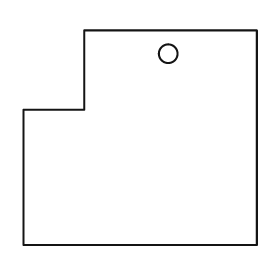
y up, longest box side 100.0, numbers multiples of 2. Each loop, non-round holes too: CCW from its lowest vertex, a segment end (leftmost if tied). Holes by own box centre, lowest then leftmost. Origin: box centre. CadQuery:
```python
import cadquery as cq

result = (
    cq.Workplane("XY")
    .moveTo(-50.0, -46.0)
    .lineTo(50.0, -46.0)
    .lineTo(50.0, 46.0)
    .lineTo(-24.0, 46.0)
    .lineTo(-24.0, 12.0)
    .lineTo(-50.0, 12.0)
    .close()
    .moveTo(12.0, 36.0)
    .circle(4.0)
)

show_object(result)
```